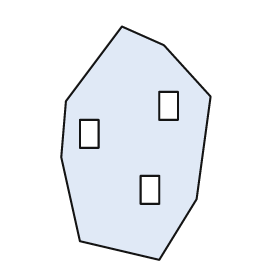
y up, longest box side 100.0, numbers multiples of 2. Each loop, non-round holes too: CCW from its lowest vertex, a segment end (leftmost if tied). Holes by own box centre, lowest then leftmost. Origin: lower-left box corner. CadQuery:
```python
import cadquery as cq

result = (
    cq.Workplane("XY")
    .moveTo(42.0, 0.0)
    .lineTo(58.0, 26.0)
    .lineTo(64.0, 70.0)
    .lineTo(44.0, 92.0)
    .lineTo(26.0, 100.0)
    .lineTo(2.0, 68.0)
    .lineTo(0.0, 44.0)
    .lineTo(8.0, 8.0)
    .close()
    .moveTo(34.0, 24.0)
    .lineTo(42.0, 24.0)
    .lineTo(42.0, 36.0)
    .lineTo(34.0, 36.0)
    .close()
    .moveTo(8.0, 48.0)
    .lineTo(16.0, 48.0)
    .lineTo(16.0, 60.0)
    .lineTo(8.0, 60.0)
    .close()
    .moveTo(42.0, 60.0)
    .lineTo(50.0, 60.0)
    .lineTo(50.0, 72.0)
    .lineTo(42.0, 72.0)
    .close()
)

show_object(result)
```